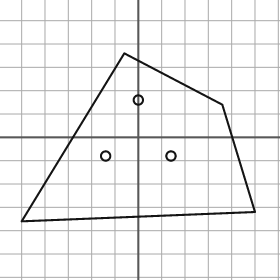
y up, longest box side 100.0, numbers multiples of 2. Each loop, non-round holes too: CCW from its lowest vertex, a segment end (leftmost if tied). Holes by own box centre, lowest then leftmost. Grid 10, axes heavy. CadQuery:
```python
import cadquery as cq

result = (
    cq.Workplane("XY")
    .moveTo(-50.0, -36.0)
    .lineTo(50.0, -32.0)
    .lineTo(36.0, 14.0)
    .lineTo(-6.0, 36.0)
    .close()
    .moveTo(-14.0, -8.0)
    .circle(2.0)
    .moveTo(14.0, -8.0)
    .circle(2.0)
    .moveTo(0.0, 16.0)
    .circle(2.0)
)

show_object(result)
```